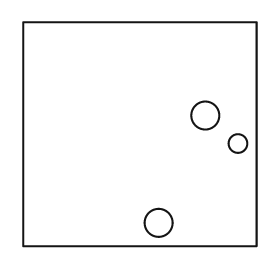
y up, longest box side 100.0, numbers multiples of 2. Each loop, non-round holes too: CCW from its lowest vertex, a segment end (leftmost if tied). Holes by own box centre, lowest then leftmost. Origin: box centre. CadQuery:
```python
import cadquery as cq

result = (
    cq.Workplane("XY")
    .moveTo(-50.0, -48.0)
    .lineTo(50.0, -48.0)
    .lineTo(50.0, 48.0)
    .lineTo(-50.0, 48.0)
    .close()
    .moveTo(8.0, -38.0)
    .circle(6.0)
    .moveTo(42.0, -4.0)
    .circle(4.0)
    .moveTo(28.0, 8.0)
    .circle(6.0)
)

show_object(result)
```